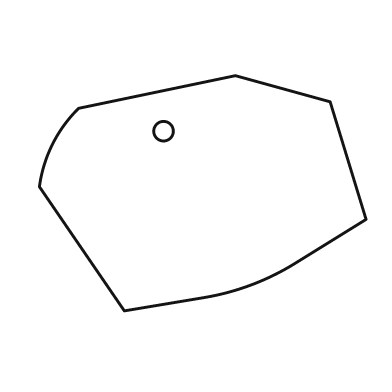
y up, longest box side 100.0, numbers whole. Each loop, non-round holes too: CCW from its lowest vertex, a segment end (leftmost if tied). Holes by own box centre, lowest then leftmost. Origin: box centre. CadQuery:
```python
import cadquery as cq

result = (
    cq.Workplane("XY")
    .moveTo(-24.0, -36.0)
    .lineTo(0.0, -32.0)
    .threePointArc((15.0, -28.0), (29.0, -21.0))
    .lineTo(50.0, -8.0)
    .lineTo(39.0, 28.0)
    .lineTo(10.0, 36.0)
    .lineTo(-38.0, 26.0)
    .threePointArc((-46.0, 15.0), (-50.0, 2.0))
    .close()
    .moveTo(-12.0, 19.0)
    .circle(3.0)
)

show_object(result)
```